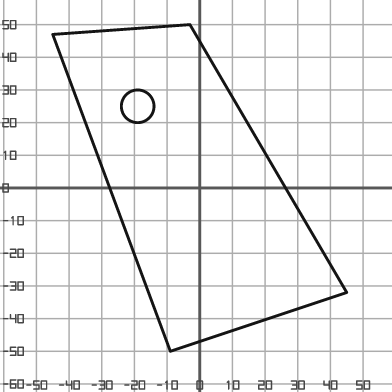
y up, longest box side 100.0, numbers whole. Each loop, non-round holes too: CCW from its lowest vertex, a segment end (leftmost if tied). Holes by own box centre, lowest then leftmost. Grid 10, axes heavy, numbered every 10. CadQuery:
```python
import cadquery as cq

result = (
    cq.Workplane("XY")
    .moveTo(-9.0, -50.0)
    .lineTo(45.0, -32.0)
    .lineTo(-3.0, 50.0)
    .lineTo(-45.0, 47.0)
    .close()
    .moveTo(-19.0, 25.0)
    .circle(5.0)
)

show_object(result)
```